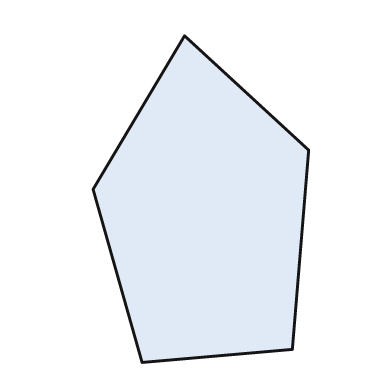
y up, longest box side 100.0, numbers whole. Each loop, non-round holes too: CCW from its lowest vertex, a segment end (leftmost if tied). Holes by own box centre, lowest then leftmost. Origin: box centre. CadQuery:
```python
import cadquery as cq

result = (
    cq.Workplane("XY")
    .moveTo(-18.0, -50.0)
    .lineTo(28.0, -46.0)
    .lineTo(33.0, 15.0)
    .lineTo(-5.0, 50.0)
    .lineTo(-33.0, 3.0)
    .close()
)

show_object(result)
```